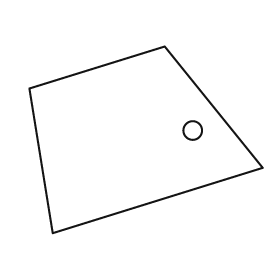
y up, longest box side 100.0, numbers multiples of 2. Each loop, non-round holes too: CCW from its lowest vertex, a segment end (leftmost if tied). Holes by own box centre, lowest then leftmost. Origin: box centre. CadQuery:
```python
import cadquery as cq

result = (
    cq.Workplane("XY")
    .moveTo(-40.0, -40.0)
    .lineTo(50.0, -12.0)
    .lineTo(8.0, 40.0)
    .lineTo(-50.0, 22.0)
    .close()
    .moveTo(20.0, 4.0)
    .circle(4.0)
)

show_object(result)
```